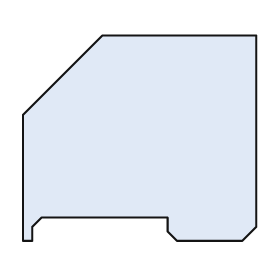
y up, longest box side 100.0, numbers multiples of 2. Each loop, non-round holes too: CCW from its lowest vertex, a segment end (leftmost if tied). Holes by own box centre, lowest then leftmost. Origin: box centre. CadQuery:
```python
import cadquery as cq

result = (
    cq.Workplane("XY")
    .moveTo(-50.0, -44.0)
    .lineTo(-46.0, -44.0)
    .lineTo(-46.0, -38.0)
    .lineTo(-42.0, -34.0)
    .lineTo(12.0, -34.0)
    .lineTo(12.0, -40.0)
    .lineTo(16.0, -44.0)
    .lineTo(44.0, -44.0)
    .lineTo(50.0, -38.0)
    .lineTo(50.0, 44.0)
    .lineTo(-16.0, 44.0)
    .lineTo(-50.0, 10.0)
    .close()
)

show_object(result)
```